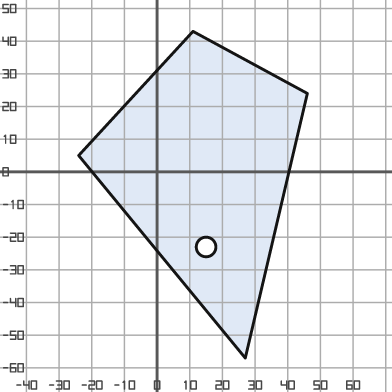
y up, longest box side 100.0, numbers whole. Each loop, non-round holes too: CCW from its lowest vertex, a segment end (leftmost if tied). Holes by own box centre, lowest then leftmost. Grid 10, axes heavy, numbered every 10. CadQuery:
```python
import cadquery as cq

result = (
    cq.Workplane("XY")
    .moveTo(27.0, -57.0)
    .lineTo(46.0, 24.0)
    .lineTo(11.0, 43.0)
    .lineTo(-24.0, 5.0)
    .close()
    .moveTo(15.0, -23.0)
    .circle(3.0)
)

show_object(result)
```